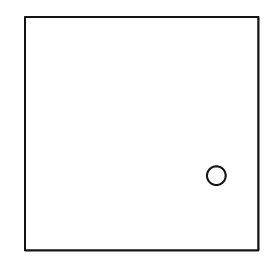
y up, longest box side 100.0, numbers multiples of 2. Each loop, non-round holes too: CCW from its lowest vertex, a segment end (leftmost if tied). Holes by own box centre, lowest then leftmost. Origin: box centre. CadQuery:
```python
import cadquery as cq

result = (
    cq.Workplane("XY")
    .moveTo(-50.0, -50.0)
    .lineTo(50.0, -50.0)
    .lineTo(50.0, 50.0)
    .lineTo(-50.0, 50.0)
    .close()
    .moveTo(32.0, -18.0)
    .circle(4.0)
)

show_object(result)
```